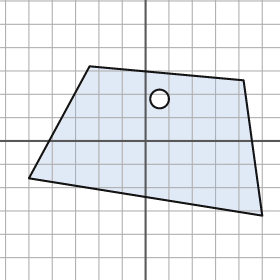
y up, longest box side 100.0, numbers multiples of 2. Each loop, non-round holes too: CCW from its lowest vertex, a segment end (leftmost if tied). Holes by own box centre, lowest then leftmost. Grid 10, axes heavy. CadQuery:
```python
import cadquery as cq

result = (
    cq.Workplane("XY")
    .moveTo(50.0, -32.0)
    .lineTo(42.0, 26.0)
    .lineTo(-24.0, 32.0)
    .lineTo(-50.0, -16.0)
    .close()
    .moveTo(6.0, 18.0)
    .circle(4.0)
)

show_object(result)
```